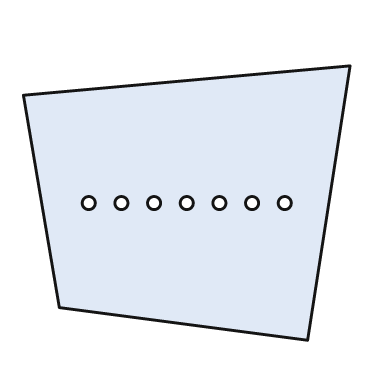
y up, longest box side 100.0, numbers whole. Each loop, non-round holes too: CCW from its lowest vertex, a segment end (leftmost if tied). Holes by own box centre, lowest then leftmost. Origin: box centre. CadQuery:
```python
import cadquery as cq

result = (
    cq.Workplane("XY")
    .moveTo(37.0, -42.0)
    .lineTo(50.0, 42.0)
    .lineTo(-50.0, 33.0)
    .lineTo(-39.0, -32.0)
    .close()
    .moveTo(-30.0, 0.0)
    .circle(2.0)
    .moveTo(-20.0, 0.0)
    .circle(2.0)
    .moveTo(-10.0, 0.0)
    .circle(2.0)
    .moveTo(0.0, 0.0)
    .circle(2.0)
    .moveTo(10.0, 0.0)
    .circle(2.0)
    .moveTo(20.0, 0.0)
    .circle(2.0)
    .moveTo(30.0, 0.0)
    .circle(2.0)
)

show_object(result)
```